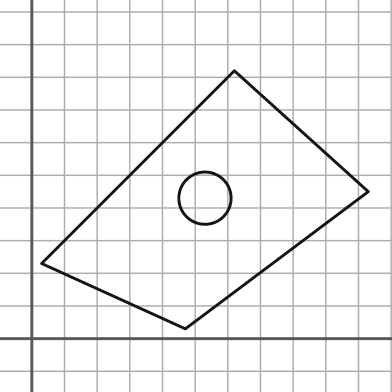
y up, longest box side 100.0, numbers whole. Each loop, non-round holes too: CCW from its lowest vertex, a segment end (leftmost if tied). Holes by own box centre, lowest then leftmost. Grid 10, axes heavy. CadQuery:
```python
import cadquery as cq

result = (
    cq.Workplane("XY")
    .moveTo(47.0, 3.0)
    .lineTo(103.0, 45.0)
    .lineTo(62.0, 82.0)
    .lineTo(3.0, 23.0)
    .close()
    .moveTo(53.0, 43.0)
    .circle(8.0)
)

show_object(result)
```